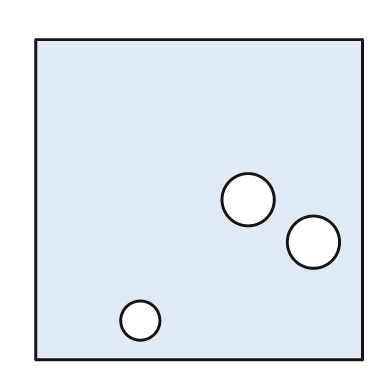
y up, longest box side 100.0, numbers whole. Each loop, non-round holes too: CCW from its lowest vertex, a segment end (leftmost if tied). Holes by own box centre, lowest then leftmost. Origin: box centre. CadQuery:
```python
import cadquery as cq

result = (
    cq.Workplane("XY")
    .moveTo(-50.0, -49.0)
    .lineTo(50.0, -49.0)
    .lineTo(50.0, 49.0)
    .lineTo(-50.0, 49.0)
    .close()
    .moveTo(-18.0, -37.0)
    .circle(6.0)
    .moveTo(35.0, -13.0)
    .circle(8.0)
    .moveTo(15.0, 0.0)
    .circle(8.0)
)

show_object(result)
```